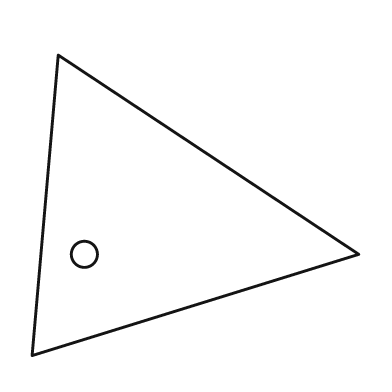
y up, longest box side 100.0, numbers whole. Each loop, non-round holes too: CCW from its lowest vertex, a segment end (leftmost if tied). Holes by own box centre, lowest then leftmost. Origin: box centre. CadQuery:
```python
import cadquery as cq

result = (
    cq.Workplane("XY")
    .moveTo(-50.0, -46.0)
    .lineTo(50.0, -15.0)
    .lineTo(-42.0, 46.0)
    .close()
    .moveTo(-34.0, -15.0)
    .circle(4.0)
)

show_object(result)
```